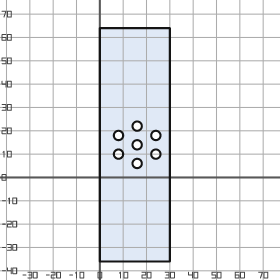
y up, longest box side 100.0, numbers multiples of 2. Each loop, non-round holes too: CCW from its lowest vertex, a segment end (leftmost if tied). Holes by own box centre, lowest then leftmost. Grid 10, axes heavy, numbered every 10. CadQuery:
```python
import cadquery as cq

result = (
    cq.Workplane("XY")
    .moveTo(0.0, -36.0)
    .lineTo(30.0, -36.0)
    .lineTo(30.0, 64.0)
    .lineTo(0.0, 64.0)
    .close()
    .moveTo(16.0, 6.0)
    .circle(2.0)
    .moveTo(8.0, 10.0)
    .circle(2.0)
    .moveTo(24.0, 10.0)
    .circle(2.0)
    .moveTo(16.0, 14.0)
    .circle(2.0)
    .moveTo(8.0, 18.0)
    .circle(2.0)
    .moveTo(24.0, 18.0)
    .circle(2.0)
    .moveTo(16.0, 22.0)
    .circle(2.0)
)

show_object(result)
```